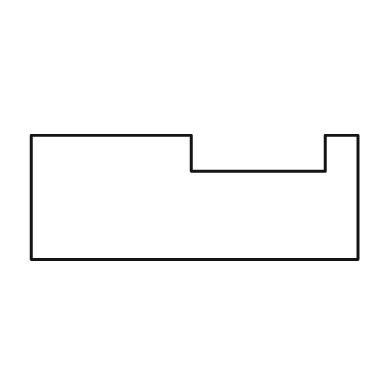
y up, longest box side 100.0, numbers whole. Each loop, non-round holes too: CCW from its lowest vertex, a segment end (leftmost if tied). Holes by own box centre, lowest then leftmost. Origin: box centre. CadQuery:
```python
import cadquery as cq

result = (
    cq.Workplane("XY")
    .moveTo(-50.0, -19.0)
    .lineTo(50.0, -19.0)
    .lineTo(50.0, 19.0)
    .lineTo(40.0, 19.0)
    .lineTo(40.0, 8.0)
    .lineTo(-1.0, 8.0)
    .lineTo(-1.0, 19.0)
    .lineTo(-50.0, 19.0)
    .close()
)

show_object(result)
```